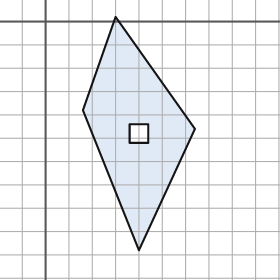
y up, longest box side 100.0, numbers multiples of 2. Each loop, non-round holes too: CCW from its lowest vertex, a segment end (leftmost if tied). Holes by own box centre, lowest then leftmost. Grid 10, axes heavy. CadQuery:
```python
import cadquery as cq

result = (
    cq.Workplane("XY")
    .moveTo(40.0, -98.0)
    .lineTo(64.0, -46.0)
    .lineTo(30.0, 2.0)
    .lineTo(16.0, -38.0)
    .close()
    .moveTo(36.0, -52.0)
    .lineTo(44.0, -52.0)
    .lineTo(44.0, -44.0)
    .lineTo(36.0, -44.0)
    .close()
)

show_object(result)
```